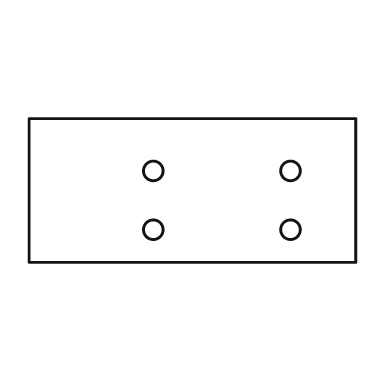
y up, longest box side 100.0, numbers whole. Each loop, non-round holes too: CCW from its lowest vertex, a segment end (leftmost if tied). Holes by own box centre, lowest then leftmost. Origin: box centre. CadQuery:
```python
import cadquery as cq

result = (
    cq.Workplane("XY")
    .moveTo(-50.0, -22.0)
    .lineTo(50.0, -22.0)
    .lineTo(50.0, 22.0)
    .lineTo(-50.0, 22.0)
    .close()
    .moveTo(-12.0, -12.0)
    .circle(3.0)
    .moveTo(30.0, -12.0)
    .circle(3.0)
    .moveTo(-12.0, 6.0)
    .circle(3.0)
    .moveTo(30.0, 6.0)
    .circle(3.0)
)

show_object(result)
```